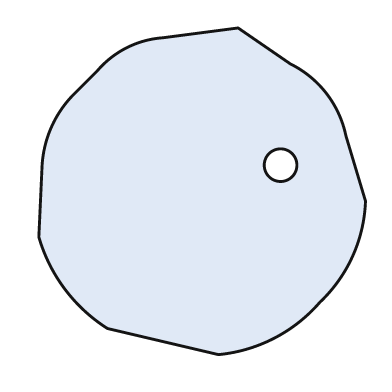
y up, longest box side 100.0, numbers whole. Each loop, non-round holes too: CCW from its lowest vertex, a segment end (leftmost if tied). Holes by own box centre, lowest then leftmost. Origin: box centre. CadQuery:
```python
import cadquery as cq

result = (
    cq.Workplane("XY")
    .moveTo(5.0, -50.0)
    .threePointArc((22.0, -45.0), (36.0, -34.0))
    .threePointArc((46.0, -20.0), (50.0, -3.0))
    .lineTo(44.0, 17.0)
    .threePointArc((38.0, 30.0), (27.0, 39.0))
    .lineTo(11.0, 50.0)
    .lineTo(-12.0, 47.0)
    .threePointArc((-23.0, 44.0), (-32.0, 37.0))
    .lineTo(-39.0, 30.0)
    .threePointArc((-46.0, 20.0), (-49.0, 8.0))
    .lineTo(-50.0, -14.0)
    .threePointArc((-42.0, -30.0), (-29.0, -42.0))
    .close()
    .moveTo(24.0, 8.0)
    .circle(5.0)
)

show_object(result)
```